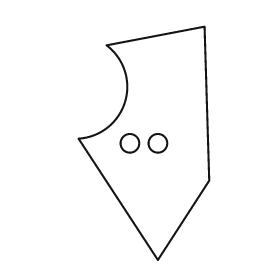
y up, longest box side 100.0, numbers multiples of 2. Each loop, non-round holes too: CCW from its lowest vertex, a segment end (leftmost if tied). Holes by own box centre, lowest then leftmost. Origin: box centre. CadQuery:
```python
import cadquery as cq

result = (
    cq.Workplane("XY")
    .moveTo(6.0, -50.0)
    .lineTo(28.0, -16.0)
    .lineTo(26.0, 50.0)
    .lineTo(-16.0, 42.0)
    .threePointArc((-8.0, 18.0), (-28.0, 2.0))
    .close()
    .moveTo(-6.0, 0.0)
    .circle(4.0)
    .moveTo(6.0, 0.0)
    .circle(4.0)
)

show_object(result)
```